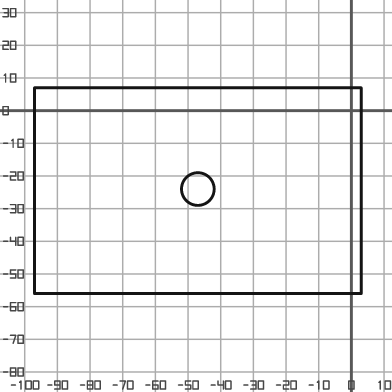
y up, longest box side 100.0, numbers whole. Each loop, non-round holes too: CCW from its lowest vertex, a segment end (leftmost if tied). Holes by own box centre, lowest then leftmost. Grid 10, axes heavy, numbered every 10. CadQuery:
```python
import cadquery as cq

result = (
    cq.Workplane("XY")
    .moveTo(-97.0, -56.0)
    .lineTo(3.0, -56.0)
    .lineTo(3.0, 7.0)
    .lineTo(-97.0, 7.0)
    .close()
    .moveTo(-47.0, -24.0)
    .circle(5.0)
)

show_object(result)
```